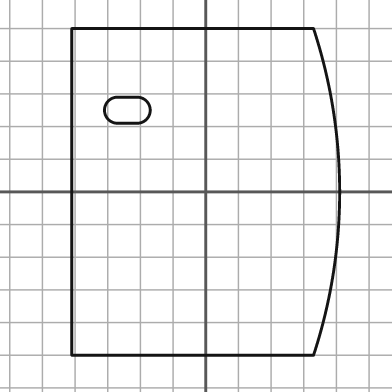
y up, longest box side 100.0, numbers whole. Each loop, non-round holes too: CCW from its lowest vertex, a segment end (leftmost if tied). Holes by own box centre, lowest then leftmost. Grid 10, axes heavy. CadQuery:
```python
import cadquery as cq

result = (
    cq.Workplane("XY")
    .moveTo(-41.0, -50.0)
    .lineTo(33.0, -50.0)
    .threePointArc((41.0, 0.0), (33.0, 50.0))
    .lineTo(-41.0, 50.0)
    .close()
    .moveTo(-27.0, 21.0)
    .lineTo(-21.0, 21.0)
    .threePointArc((-17.0, 25.0), (-21.0, 29.0))
    .lineTo(-27.0, 29.0)
    .threePointArc((-31.0, 25.0), (-27.0, 21.0))
    .close()
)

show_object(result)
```